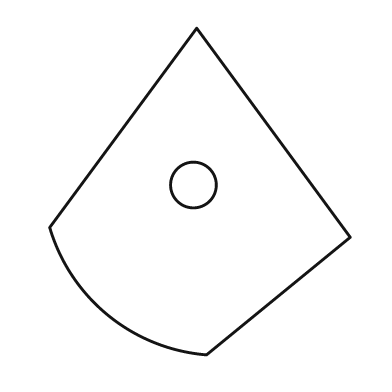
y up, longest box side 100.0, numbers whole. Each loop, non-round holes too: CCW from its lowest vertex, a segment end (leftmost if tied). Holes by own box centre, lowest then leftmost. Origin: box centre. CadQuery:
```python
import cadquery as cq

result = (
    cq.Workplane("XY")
    .moveTo(2.0, -50.0)
    .lineTo(46.0, -14.0)
    .lineTo(-1.0, 50.0)
    .lineTo(-46.0, -11.0)
    .threePointArc((-28.0, -38.0), (2.0, -50.0))
    .close()
    .moveTo(-2.0, 2.0)
    .circle(7.0)
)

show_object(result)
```